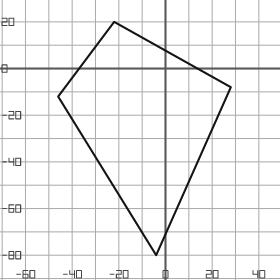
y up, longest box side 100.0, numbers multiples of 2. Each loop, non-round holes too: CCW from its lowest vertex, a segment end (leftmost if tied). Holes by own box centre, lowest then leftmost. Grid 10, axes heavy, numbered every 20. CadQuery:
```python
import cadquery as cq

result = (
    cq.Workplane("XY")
    .moveTo(-4.0, -80.0)
    .lineTo(28.0, -8.0)
    .lineTo(-22.0, 20.0)
    .lineTo(-46.0, -12.0)
    .close()
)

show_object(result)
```